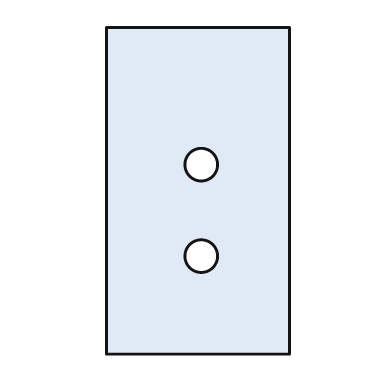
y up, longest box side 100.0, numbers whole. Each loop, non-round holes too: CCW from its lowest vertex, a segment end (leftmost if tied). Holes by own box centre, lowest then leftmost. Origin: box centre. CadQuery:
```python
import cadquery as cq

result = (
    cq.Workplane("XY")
    .moveTo(-28.0, -50.0)
    .lineTo(28.0, -50.0)
    .lineTo(28.0, 50.0)
    .lineTo(-28.0, 50.0)
    .close()
    .moveTo(1.0, -20.0)
    .circle(5.0)
    .moveTo(1.0, 8.0)
    .circle(5.0)
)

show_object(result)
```